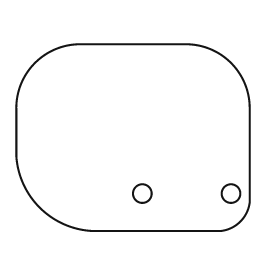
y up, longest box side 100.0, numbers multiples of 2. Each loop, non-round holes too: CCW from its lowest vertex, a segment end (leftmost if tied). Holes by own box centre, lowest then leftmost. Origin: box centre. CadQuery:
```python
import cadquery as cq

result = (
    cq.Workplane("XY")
    .moveTo(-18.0, -40.0)
    .lineTo(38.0, -40.0)
    .threePointArc((46.0, -36.0), (50.0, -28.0))
    .lineTo(50.0, 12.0)
    .threePointArc((42.0, 32.0), (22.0, 40.0))
    .lineTo(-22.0, 40.0)
    .threePointArc((-42.0, 32.0), (-50.0, 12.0))
    .lineTo(-50.0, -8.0)
    .threePointArc((-40.0, -30.0), (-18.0, -40.0))
    .close()
    .moveTo(4.0, -24.0)
    .circle(4.0)
    .moveTo(42.0, -24.0)
    .circle(4.0)
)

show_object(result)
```